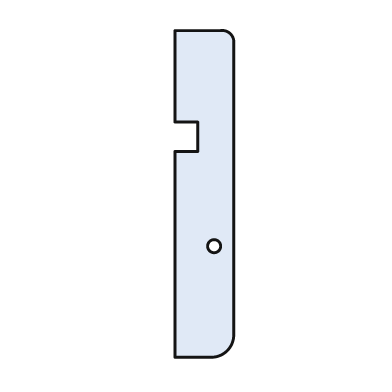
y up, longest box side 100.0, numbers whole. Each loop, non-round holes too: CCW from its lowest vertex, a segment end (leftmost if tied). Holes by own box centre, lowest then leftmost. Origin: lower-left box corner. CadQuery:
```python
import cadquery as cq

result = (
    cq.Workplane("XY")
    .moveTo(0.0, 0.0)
    .lineTo(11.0, 0.0)
    .threePointArc((16.0, 2.0), (18.0, 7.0))
    .lineTo(18.0, 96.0)
    .threePointArc((17.0, 99.0), (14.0, 100.0))
    .lineTo(0.0, 100.0)
    .lineTo(0.0, 72.0)
    .lineTo(7.0, 72.0)
    .lineTo(7.0, 63.0)
    .lineTo(0.0, 63.0)
    .close()
    .moveTo(12.0, 34.0)
    .circle(2.0)
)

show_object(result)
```